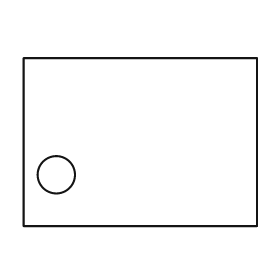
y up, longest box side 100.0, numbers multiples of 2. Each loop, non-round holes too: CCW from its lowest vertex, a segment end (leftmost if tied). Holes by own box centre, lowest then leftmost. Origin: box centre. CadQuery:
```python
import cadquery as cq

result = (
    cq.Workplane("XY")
    .moveTo(-50.0, -36.0)
    .lineTo(50.0, -36.0)
    .lineTo(50.0, 36.0)
    .lineTo(-50.0, 36.0)
    .close()
    .moveTo(-36.0, -14.0)
    .circle(8.0)
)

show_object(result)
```